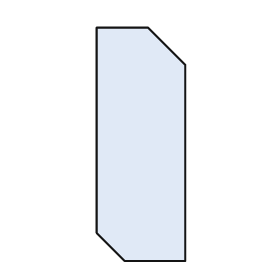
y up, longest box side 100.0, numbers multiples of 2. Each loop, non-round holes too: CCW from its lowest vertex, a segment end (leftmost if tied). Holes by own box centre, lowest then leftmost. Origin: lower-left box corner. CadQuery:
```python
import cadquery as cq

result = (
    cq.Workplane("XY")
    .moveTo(12.0, 0.0)
    .lineTo(38.0, 0.0)
    .lineTo(38.0, 84.0)
    .lineTo(22.0, 100.0)
    .lineTo(0.0, 100.0)
    .lineTo(0.0, 12.0)
    .close()
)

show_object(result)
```